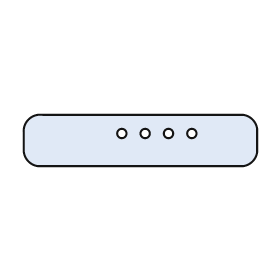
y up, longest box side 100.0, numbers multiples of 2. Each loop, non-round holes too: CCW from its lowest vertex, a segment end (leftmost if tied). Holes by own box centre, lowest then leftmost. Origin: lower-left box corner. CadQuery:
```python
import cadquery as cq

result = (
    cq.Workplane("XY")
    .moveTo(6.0, 0.0)
    .lineTo(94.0, 0.0)
    .threePointArc((98.0, 2.0), (100.0, 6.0))
    .lineTo(100.0, 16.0)
    .threePointArc((98.0, 20.0), (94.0, 22.0))
    .lineTo(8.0, 22.0)
    .threePointArc((2.0, 20.0), (0.0, 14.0))
    .lineTo(0.0, 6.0)
    .threePointArc((2.0, 2.0), (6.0, 0.0))
    .close()
    .moveTo(42.0, 14.0)
    .circle(2.0)
    .moveTo(52.0, 14.0)
    .circle(2.0)
    .moveTo(62.0, 14.0)
    .circle(2.0)
    .moveTo(72.0, 14.0)
    .circle(2.0)
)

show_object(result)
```